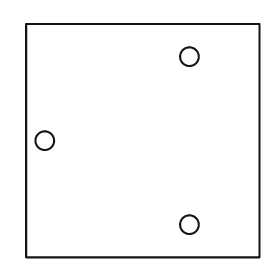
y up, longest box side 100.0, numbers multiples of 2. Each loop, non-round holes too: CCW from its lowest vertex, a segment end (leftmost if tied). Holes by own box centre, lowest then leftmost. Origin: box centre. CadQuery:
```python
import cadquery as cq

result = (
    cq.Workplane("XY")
    .moveTo(-50.0, -50.0)
    .lineTo(50.0, -50.0)
    .lineTo(50.0, 50.0)
    .lineTo(-50.0, 50.0)
    .close()
    .moveTo(20.0, -36.0)
    .circle(4.0)
    .moveTo(-42.0, 0.0)
    .circle(4.0)
    .moveTo(20.0, 36.0)
    .circle(4.0)
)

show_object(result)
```